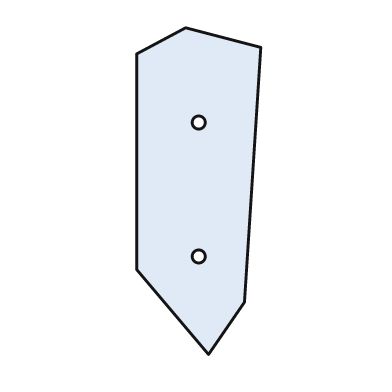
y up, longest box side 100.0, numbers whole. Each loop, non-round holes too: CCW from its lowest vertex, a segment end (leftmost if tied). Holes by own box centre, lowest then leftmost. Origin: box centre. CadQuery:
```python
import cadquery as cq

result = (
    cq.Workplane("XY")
    .moveTo(3.0, -50.0)
    .lineTo(14.0, -34.0)
    .lineTo(19.0, 44.0)
    .lineTo(-4.0, 50.0)
    .lineTo(-19.0, 42.0)
    .lineTo(-19.0, -24.0)
    .close()
    .moveTo(0.0, -20.0)
    .circle(2.0)
    .moveTo(0.0, 21.0)
    .circle(2.0)
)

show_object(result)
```